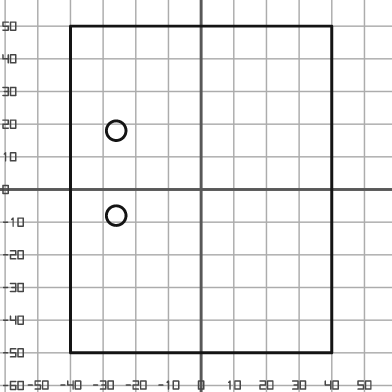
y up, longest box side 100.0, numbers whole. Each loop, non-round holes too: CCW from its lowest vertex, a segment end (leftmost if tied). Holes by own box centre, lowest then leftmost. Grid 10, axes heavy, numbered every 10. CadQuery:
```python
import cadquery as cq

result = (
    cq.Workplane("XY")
    .moveTo(-40.0, -50.0)
    .lineTo(40.0, -50.0)
    .lineTo(40.0, 50.0)
    .lineTo(-40.0, 50.0)
    .close()
    .moveTo(-26.0, -8.0)
    .circle(3.0)
    .moveTo(-26.0, 18.0)
    .circle(3.0)
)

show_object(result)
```